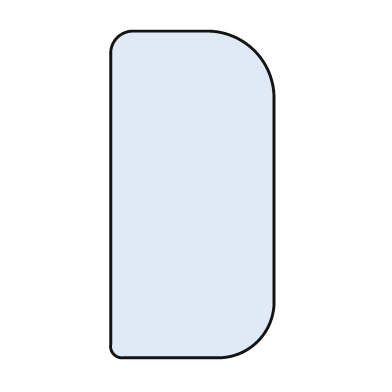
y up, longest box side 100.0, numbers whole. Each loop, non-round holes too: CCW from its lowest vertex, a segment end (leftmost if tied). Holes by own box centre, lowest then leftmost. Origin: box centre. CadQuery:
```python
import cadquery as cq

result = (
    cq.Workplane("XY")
    .moveTo(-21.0, -50.0)
    .lineTo(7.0, -50.0)
    .threePointArc((20.0, -45.0), (25.0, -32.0))
    .lineTo(25.0, 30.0)
    .threePointArc((19.0, 44.0), (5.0, 50.0))
    .lineTo(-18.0, 50.0)
    .threePointArc((-23.0, 48.0), (-25.0, 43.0))
    .lineTo(-25.0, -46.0)
    .threePointArc((-24.0, -49.0), (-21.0, -50.0))
    .close()
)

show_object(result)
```